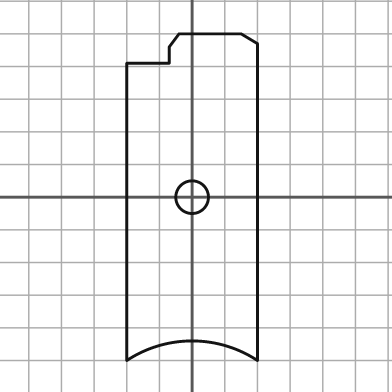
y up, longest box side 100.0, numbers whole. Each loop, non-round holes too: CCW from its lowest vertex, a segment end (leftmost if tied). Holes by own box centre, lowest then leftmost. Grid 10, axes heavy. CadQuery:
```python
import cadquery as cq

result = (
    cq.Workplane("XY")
    .moveTo(-20.0, -50.0)
    .threePointArc((0.0, -44.0), (20.0, -50.0))
    .lineTo(20.0, 47.0)
    .lineTo(15.0, 50.0)
    .lineTo(-4.0, 50.0)
    .lineTo(-7.0, 46.0)
    .lineTo(-7.0, 41.0)
    .lineTo(-20.0, 41.0)
    .close()
    .moveTo(0.0, 0.0)
    .circle(5.0)
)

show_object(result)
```